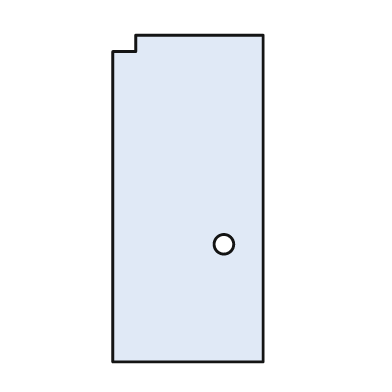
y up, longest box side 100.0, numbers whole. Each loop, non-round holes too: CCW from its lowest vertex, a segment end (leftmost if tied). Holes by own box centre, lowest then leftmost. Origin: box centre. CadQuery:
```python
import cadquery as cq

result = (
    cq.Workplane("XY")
    .moveTo(-23.0, -50.0)
    .lineTo(23.0, -50.0)
    .lineTo(23.0, 50.0)
    .lineTo(-16.0, 50.0)
    .lineTo(-16.0, 45.0)
    .lineTo(-23.0, 45.0)
    .close()
    .moveTo(11.0, -14.0)
    .circle(3.0)
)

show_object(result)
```